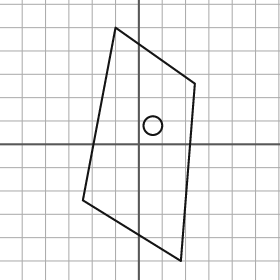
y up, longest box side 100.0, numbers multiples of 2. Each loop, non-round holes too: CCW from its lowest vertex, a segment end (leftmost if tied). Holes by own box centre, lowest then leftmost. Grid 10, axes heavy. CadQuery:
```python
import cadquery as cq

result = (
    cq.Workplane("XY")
    .moveTo(18.0, -50.0)
    .lineTo(24.0, 26.0)
    .lineTo(-10.0, 50.0)
    .lineTo(-24.0, -24.0)
    .close()
    .moveTo(6.0, 8.0)
    .circle(4.0)
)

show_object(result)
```